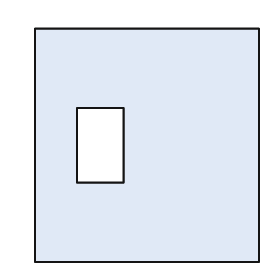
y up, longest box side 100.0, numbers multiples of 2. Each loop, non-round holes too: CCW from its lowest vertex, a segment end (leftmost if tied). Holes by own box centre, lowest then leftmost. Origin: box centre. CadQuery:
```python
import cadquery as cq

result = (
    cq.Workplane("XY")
    .moveTo(-48.0, -50.0)
    .lineTo(48.0, -50.0)
    .lineTo(48.0, 50.0)
    .lineTo(-48.0, 50.0)
    .close()
    .moveTo(-30.0, -16.0)
    .lineTo(-10.0, -16.0)
    .lineTo(-10.0, 16.0)
    .lineTo(-30.0, 16.0)
    .close()
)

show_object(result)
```